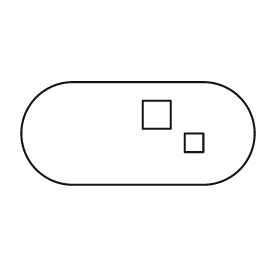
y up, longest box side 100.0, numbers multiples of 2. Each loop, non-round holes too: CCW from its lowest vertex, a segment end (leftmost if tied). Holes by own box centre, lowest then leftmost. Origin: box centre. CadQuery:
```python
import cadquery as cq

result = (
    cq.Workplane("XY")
    .moveTo(-28.0, -22.0)
    .lineTo(28.0, -22.0)
    .threePointArc((50.0, 0.0), (28.0, 22.0))
    .lineTo(-28.0, 22.0)
    .threePointArc((-50.0, 0.0), (-28.0, -22.0))
    .close()
    .moveTo(20.0, -8.0)
    .lineTo(28.0, -8.0)
    .lineTo(28.0, 0.0)
    .lineTo(20.0, 0.0)
    .close()
    .moveTo(2.0, 2.0)
    .lineTo(14.0, 2.0)
    .lineTo(14.0, 14.0)
    .lineTo(2.0, 14.0)
    .close()
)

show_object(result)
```